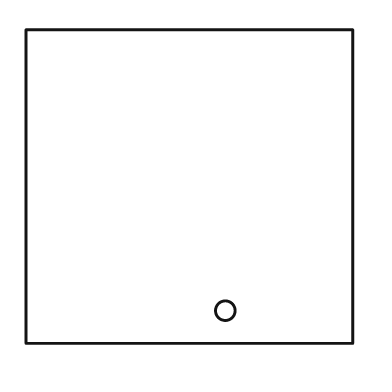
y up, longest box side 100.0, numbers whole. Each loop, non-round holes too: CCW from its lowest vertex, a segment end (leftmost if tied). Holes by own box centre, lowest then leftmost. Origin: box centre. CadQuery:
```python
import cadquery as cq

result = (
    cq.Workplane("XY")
    .moveTo(-50.0, -48.0)
    .lineTo(50.0, -48.0)
    .lineTo(50.0, 48.0)
    .lineTo(-50.0, 48.0)
    .close()
    .moveTo(11.0, -38.0)
    .circle(3.0)
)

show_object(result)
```